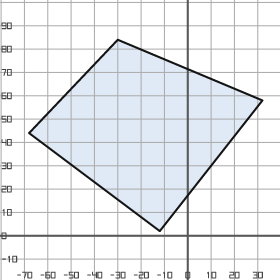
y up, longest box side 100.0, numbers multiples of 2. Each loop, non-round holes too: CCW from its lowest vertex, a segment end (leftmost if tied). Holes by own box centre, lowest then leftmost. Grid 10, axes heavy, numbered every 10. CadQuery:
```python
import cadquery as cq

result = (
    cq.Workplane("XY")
    .moveTo(-12.0, 2.0)
    .lineTo(32.0, 58.0)
    .lineTo(-30.0, 84.0)
    .lineTo(-68.0, 44.0)
    .close()
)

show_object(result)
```